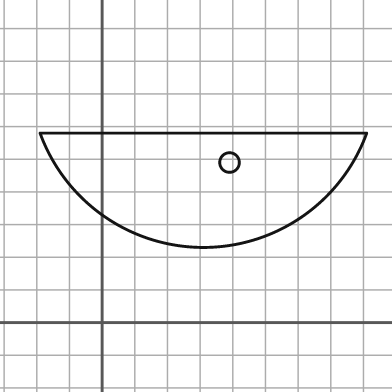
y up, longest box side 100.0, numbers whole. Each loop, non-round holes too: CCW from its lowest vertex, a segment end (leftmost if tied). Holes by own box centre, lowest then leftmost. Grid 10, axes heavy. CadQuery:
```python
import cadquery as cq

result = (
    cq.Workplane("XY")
    .moveTo(-19.0, 58.0)
    .threePointArc((31.0, 23.0), (81.0, 58.0))
    .close()
    .moveTo(39.0, 49.0)
    .circle(3.0)
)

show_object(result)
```